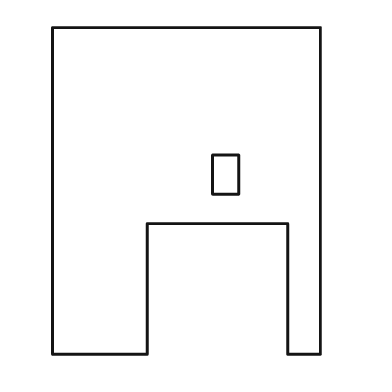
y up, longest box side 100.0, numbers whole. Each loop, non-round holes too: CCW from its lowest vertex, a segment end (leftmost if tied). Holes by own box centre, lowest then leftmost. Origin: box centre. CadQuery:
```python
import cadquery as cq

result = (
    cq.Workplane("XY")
    .moveTo(-41.0, -50.0)
    .lineTo(-12.0, -50.0)
    .lineTo(-12.0, -10.0)
    .lineTo(31.0, -10.0)
    .lineTo(31.0, -50.0)
    .lineTo(41.0, -50.0)
    .lineTo(41.0, 50.0)
    .lineTo(-41.0, 50.0)
    .close()
    .moveTo(8.0, -1.0)
    .lineTo(16.0, -1.0)
    .lineTo(16.0, 11.0)
    .lineTo(8.0, 11.0)
    .close()
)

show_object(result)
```